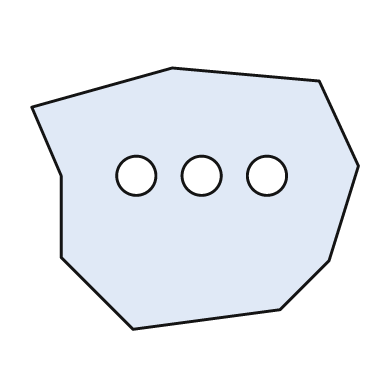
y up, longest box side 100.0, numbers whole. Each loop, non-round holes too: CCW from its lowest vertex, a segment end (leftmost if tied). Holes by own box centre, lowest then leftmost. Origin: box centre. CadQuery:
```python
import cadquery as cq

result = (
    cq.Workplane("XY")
    .moveTo(-19.0, -40.0)
    .lineTo(26.0, -34.0)
    .lineTo(41.0, -19.0)
    .lineTo(50.0, 10.0)
    .lineTo(38.0, 36.0)
    .lineTo(-7.0, 40.0)
    .lineTo(-50.0, 28.0)
    .lineTo(-41.0, 7.0)
    .lineTo(-41.0, -18.0)
    .close()
    .moveTo(-18.0, 7.0)
    .circle(6.0)
    .moveTo(2.0, 7.0)
    .circle(6.0)
    .moveTo(22.0, 7.0)
    .circle(6.0)
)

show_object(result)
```